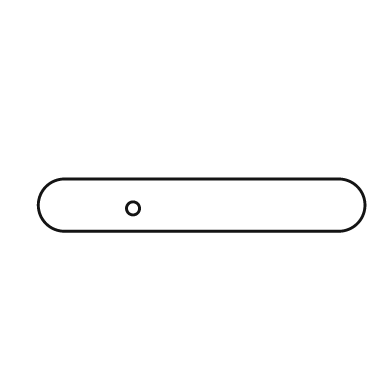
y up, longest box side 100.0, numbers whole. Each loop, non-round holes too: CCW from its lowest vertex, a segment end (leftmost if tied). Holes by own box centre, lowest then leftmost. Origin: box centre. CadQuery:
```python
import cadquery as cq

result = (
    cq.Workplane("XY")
    .moveTo(-42.0, -8.0)
    .lineTo(42.0, -8.0)
    .threePointArc((50.0, 0.0), (42.0, 8.0))
    .lineTo(-42.0, 8.0)
    .threePointArc((-50.0, 0.0), (-42.0, -8.0))
    .close()
    .moveTo(-21.0, -1.0)
    .circle(2.0)
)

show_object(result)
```